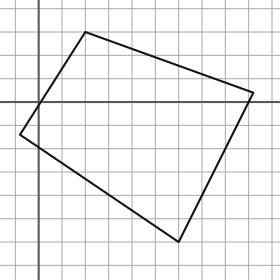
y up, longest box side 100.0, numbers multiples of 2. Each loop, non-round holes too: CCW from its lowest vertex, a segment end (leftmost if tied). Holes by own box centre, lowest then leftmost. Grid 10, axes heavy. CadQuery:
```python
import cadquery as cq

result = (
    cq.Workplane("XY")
    .moveTo(60.0, -60.0)
    .lineTo(92.0, 4.0)
    .lineTo(20.0, 30.0)
    .lineTo(-8.0, -14.0)
    .close()
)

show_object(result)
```